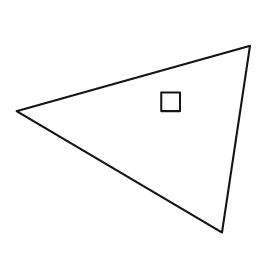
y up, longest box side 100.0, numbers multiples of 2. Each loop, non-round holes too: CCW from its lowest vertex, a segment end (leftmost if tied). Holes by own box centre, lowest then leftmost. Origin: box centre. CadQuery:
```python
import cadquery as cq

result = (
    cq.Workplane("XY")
    .moveTo(38.0, -40.0)
    .lineTo(50.0, 40.0)
    .lineTo(-50.0, 12.0)
    .close()
    .moveTo(12.0, 12.0)
    .lineTo(20.0, 12.0)
    .lineTo(20.0, 20.0)
    .lineTo(12.0, 20.0)
    .close()
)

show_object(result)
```